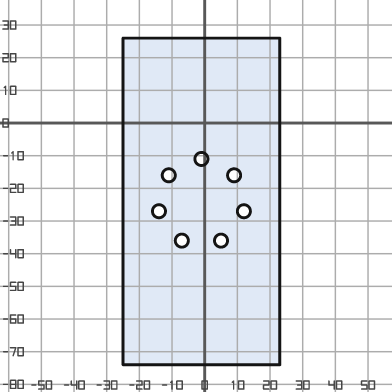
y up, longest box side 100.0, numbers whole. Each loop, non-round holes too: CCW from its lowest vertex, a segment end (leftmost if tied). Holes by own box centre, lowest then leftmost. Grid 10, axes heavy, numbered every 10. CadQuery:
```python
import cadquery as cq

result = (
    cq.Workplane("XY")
    .moveTo(-25.0, -74.0)
    .lineTo(23.0, -74.0)
    .lineTo(23.0, 26.0)
    .lineTo(-25.0, 26.0)
    .close()
    .moveTo(-7.0, -36.0)
    .circle(2.0)
    .moveTo(5.0, -36.0)
    .circle(2.0)
    .moveTo(-14.0, -27.0)
    .circle(2.0)
    .moveTo(12.0, -27.0)
    .circle(2.0)
    .moveTo(-11.0, -16.0)
    .circle(2.0)
    .moveTo(9.0, -16.0)
    .circle(2.0)
    .moveTo(-1.0, -11.0)
    .circle(2.0)
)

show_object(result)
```